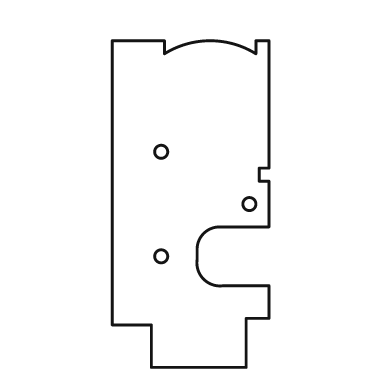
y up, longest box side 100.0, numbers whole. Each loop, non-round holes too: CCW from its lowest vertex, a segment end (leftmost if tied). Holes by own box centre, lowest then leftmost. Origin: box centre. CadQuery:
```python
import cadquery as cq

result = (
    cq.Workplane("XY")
    .moveTo(-12.0, -50.0)
    .lineTo(17.0, -50.0)
    .lineTo(17.0, -35.0)
    .lineTo(24.0, -35.0)
    .lineTo(24.0, -25.0)
    .lineTo(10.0, -25.0)
    .threePointArc((4.0, -23.0), (2.0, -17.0))
    .lineTo(2.0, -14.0)
    .threePointArc((4.0, -9.0), (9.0, -7.0))
    .lineTo(24.0, -7.0)
    .lineTo(24.0, 7.0)
    .lineTo(21.0, 7.0)
    .lineTo(21.0, 11.0)
    .lineTo(24.0, 11.0)
    .lineTo(24.0, 50.0)
    .lineTo(20.0, 50.0)
    .lineTo(20.0, 46.0)
    .threePointArc((6.0, 50.0), (-8.0, 46.0))
    .lineTo(-8.0, 50.0)
    .lineTo(-24.0, 50.0)
    .lineTo(-24.0, -37.0)
    .lineTo(-12.0, -37.0)
    .close()
    .moveTo(-9.0, -16.0)
    .circle(2.0)
    .moveTo(18.0, 0.0)
    .circle(2.0)
    .moveTo(-9.0, 16.0)
    .circle(2.0)
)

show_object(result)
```